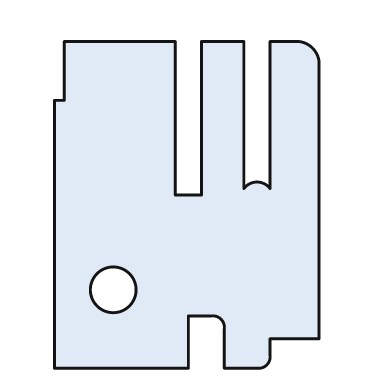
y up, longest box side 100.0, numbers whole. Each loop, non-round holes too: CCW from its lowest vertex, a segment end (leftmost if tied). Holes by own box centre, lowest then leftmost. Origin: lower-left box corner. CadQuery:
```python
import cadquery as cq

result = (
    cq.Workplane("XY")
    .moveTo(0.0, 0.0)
    .lineTo(41.0, 0.0)
    .lineTo(41.0, 16.0)
    .lineTo(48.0, 16.0)
    .threePointArc((51.0, 15.0), (52.0, 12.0))
    .lineTo(52.0, 0.0)
    .lineTo(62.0, 0.0)
    .threePointArc((65.0, 1.0), (66.0, 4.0))
    .lineTo(66.0, 9.0)
    .lineTo(81.0, 9.0)
    .lineTo(81.0, 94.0)
    .threePointArc((79.0, 98.0), (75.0, 100.0))
    .lineTo(66.0, 100.0)
    .lineTo(66.0, 55.0)
    .threePointArc((62.0, 57.0), (58.0, 55.0))
    .lineTo(58.0, 100.0)
    .lineTo(45.0, 100.0)
    .lineTo(45.0, 53.0)
    .lineTo(37.0, 53.0)
    .lineTo(37.0, 100.0)
    .lineTo(3.0, 100.0)
    .lineTo(3.0, 82.0)
    .lineTo(0.0, 82.0)
    .close()
    .moveTo(18.0, 24.0)
    .circle(7.0)
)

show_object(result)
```